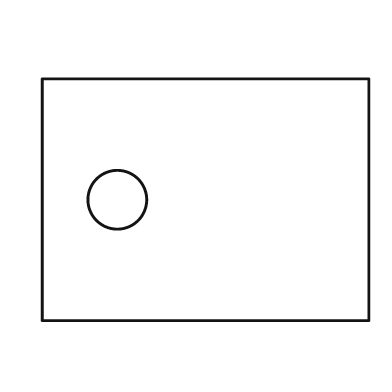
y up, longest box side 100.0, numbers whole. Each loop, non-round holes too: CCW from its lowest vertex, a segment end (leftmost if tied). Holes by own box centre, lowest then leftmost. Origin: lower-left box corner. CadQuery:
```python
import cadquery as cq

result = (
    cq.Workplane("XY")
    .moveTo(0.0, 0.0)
    .lineTo(100.0, 0.0)
    .lineTo(100.0, 74.0)
    .lineTo(0.0, 74.0)
    .close()
    .moveTo(23.0, 37.0)
    .circle(9.0)
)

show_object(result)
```